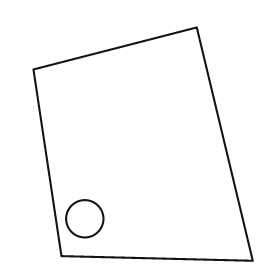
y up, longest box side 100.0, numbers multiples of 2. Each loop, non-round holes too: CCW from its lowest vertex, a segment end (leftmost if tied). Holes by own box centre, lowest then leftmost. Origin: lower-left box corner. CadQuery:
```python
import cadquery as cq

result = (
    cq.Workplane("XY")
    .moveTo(94.0, 0.0)
    .lineTo(70.0, 100.0)
    .lineTo(0.0, 82.0)
    .lineTo(12.0, 2.0)
    .close()
    .moveTo(22.0, 18.0)
    .circle(8.0)
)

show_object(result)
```